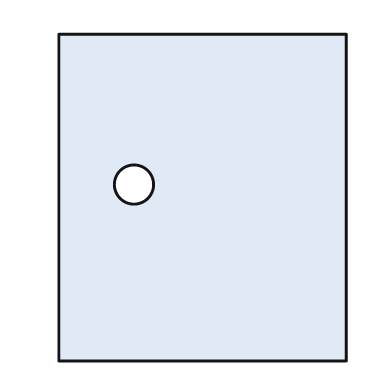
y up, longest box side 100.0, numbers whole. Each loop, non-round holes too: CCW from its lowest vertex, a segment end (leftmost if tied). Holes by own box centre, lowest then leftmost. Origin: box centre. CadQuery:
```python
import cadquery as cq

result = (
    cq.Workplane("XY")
    .moveTo(-44.0, -50.0)
    .lineTo(44.0, -50.0)
    .lineTo(44.0, 50.0)
    .lineTo(-44.0, 50.0)
    .close()
    .moveTo(-21.0, 4.0)
    .circle(6.0)
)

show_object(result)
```